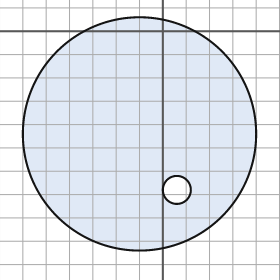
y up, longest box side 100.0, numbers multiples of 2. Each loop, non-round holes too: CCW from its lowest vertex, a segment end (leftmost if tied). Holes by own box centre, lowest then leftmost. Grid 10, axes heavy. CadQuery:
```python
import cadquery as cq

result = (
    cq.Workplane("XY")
    .moveTo(-10.0, -44.0)
    .circle(50.0)
    .moveTo(6.0, -68.0)
    .circle(6.0)
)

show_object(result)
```